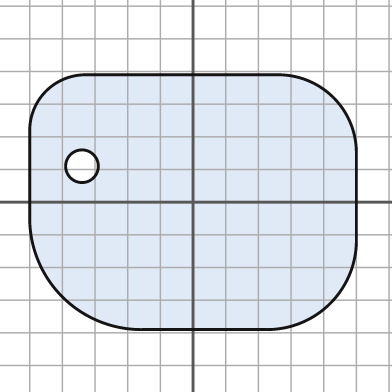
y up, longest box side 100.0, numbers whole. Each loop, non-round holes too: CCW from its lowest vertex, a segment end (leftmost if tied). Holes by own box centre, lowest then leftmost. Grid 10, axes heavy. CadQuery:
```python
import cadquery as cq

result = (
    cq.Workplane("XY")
    .moveTo(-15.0, -39.0)
    .lineTo(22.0, -39.0)
    .threePointArc((42.0, -31.0), (50.0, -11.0))
    .lineTo(50.0, 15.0)
    .threePointArc((43.0, 32.0), (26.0, 39.0))
    .lineTo(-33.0, 39.0)
    .threePointArc((-45.0, 34.0), (-50.0, 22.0))
    .lineTo(-50.0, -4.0)
    .threePointArc((-40.0, -29.0), (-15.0, -39.0))
    .close()
    .moveTo(-34.0, 11.0)
    .circle(5.0)
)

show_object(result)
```